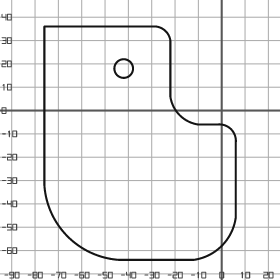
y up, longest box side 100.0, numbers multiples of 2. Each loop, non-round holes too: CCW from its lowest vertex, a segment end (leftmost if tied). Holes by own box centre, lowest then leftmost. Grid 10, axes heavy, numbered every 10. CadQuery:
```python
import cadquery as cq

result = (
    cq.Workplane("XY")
    .moveTo(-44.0, -64.0)
    .lineTo(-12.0, -64.0)
    .threePointArc((0.0, -58.0), (6.0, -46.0))
    .lineTo(6.0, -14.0)
    .threePointArc((4.0, -8.0), (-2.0, -6.0))
    .lineTo(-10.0, -6.0)
    .threePointArc((-18.0, -2.0), (-22.0, 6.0))
    .lineTo(-22.0, 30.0)
    .threePointArc((-24.0, 34.0), (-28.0, 36.0))
    .lineTo(-76.0, 36.0)
    .lineTo(-76.0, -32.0)
    .threePointArc((-66.0, -54.0), (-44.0, -64.0))
    .close()
    .moveTo(-42.0, 18.0)
    .circle(4.0)
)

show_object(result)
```